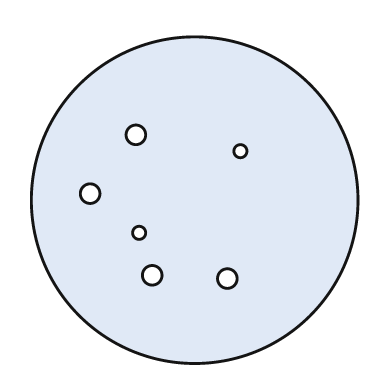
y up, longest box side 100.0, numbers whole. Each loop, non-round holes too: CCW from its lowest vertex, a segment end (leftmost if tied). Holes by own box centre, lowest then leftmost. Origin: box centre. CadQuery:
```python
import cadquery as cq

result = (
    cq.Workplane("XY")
    .moveTo(0.0, 0.0)
    .circle(50.0)
    .moveTo(10.0, -24.0)
    .circle(3.0)
    .moveTo(-13.0, -23.0)
    .circle(3.0)
    .moveTo(-17.0, -10.0)
    .circle(2.0)
    .moveTo(-32.0, 2.0)
    .circle(3.0)
    .moveTo(14.0, 15.0)
    .circle(2.0)
    .moveTo(-18.0, 20.0)
    .circle(3.0)
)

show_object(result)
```